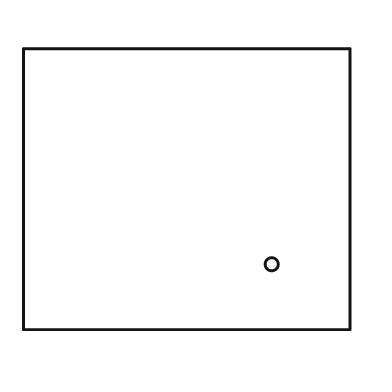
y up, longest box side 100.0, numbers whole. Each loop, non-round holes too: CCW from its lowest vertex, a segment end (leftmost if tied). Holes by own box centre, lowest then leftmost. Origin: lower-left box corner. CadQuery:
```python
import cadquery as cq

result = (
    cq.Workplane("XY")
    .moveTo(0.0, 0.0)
    .lineTo(100.0, 0.0)
    .lineTo(100.0, 86.0)
    .lineTo(0.0, 86.0)
    .close()
    .moveTo(76.0, 20.0)
    .circle(2.0)
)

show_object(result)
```